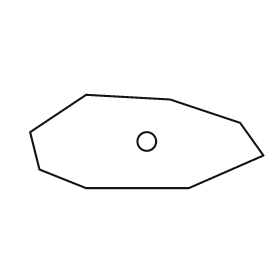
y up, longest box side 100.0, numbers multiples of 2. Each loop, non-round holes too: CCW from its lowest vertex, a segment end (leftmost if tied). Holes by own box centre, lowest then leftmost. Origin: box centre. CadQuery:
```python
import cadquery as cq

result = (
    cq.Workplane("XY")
    .moveTo(-26.0, -20.0)
    .lineTo(18.0, -20.0)
    .lineTo(50.0, -6.0)
    .lineTo(40.0, 8.0)
    .lineTo(10.0, 18.0)
    .lineTo(-26.0, 20.0)
    .lineTo(-50.0, 4.0)
    .lineTo(-46.0, -12.0)
    .close()
    .moveTo(0.0, 0.0)
    .circle(4.0)
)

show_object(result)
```